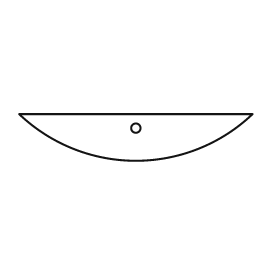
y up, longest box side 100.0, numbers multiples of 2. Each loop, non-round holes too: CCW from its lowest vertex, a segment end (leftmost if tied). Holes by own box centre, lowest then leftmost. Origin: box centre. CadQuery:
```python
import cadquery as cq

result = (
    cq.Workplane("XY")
    .moveTo(-50.0, 10.0)
    .threePointArc((0.0, -10.0), (50.0, 10.0))
    .close()
    .moveTo(0.0, 4.0)
    .circle(2.0)
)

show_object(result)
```